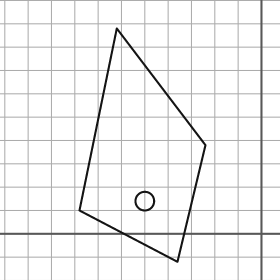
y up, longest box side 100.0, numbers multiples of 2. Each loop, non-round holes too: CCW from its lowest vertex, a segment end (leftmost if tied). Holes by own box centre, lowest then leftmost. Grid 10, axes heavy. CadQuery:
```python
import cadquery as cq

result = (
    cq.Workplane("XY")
    .moveTo(-36.0, -12.0)
    .lineTo(-24.0, 38.0)
    .lineTo(-62.0, 88.0)
    .lineTo(-78.0, 10.0)
    .close()
    .moveTo(-50.0, 14.0)
    .circle(4.0)
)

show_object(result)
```